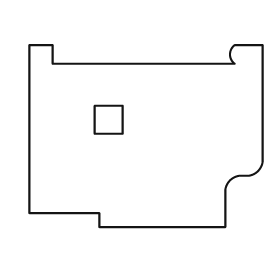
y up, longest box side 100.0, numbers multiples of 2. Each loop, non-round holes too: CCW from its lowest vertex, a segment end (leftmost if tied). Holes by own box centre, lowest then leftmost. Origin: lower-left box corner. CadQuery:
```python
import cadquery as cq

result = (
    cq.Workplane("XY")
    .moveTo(30.0, 0.0)
    .lineTo(84.0, 0.0)
    .lineTo(84.0, 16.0)
    .threePointArc((86.0, 20.0), (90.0, 22.0))
    .lineTo(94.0, 22.0)
    .threePointArc((98.0, 24.0), (100.0, 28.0))
    .lineTo(100.0, 78.0)
    .lineTo(88.0, 78.0)
    .threePointArc((86.0, 74.0), (88.0, 70.0))
    .lineTo(10.0, 70.0)
    .lineTo(10.0, 78.0)
    .lineTo(0.0, 78.0)
    .lineTo(0.0, 6.0)
    .lineTo(30.0, 6.0)
    .close()
    .moveTo(28.0, 40.0)
    .lineTo(40.0, 40.0)
    .lineTo(40.0, 52.0)
    .lineTo(28.0, 52.0)
    .close()
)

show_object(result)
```